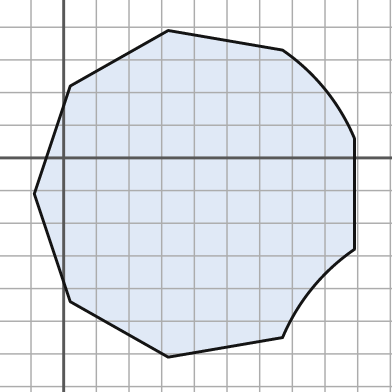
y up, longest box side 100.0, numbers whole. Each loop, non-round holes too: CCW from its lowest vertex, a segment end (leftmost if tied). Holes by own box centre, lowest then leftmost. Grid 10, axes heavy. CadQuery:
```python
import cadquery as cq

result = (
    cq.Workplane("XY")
    .moveTo(32.0, -61.0)
    .lineTo(67.0, -55.0)
    .threePointArc((76.0, -40.0), (89.0, -28.0))
    .lineTo(89.0, 6.0)
    .threePointArc((80.0, 21.0), (67.0, 33.0))
    .lineTo(32.0, 39.0)
    .lineTo(2.0, 22.0)
    .lineTo(-9.0, -11.0)
    .lineTo(2.0, -44.0)
    .close()
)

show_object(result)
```